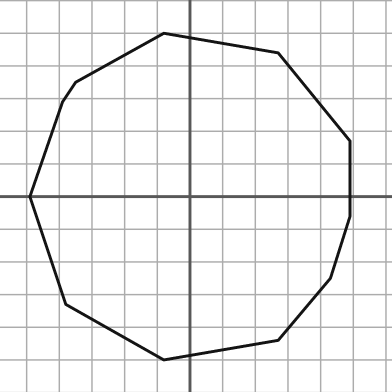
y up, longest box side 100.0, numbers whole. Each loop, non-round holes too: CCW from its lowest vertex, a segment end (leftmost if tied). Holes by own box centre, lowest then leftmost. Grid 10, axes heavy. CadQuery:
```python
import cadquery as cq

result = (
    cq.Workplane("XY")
    .moveTo(-8.0, -50.0)
    .lineTo(27.0, -44.0)
    .lineTo(43.0, -25.0)
    .lineTo(49.0, -6.0)
    .lineTo(49.0, 17.0)
    .lineTo(27.0, 44.0)
    .lineTo(-8.0, 50.0)
    .lineTo(-35.0, 35.0)
    .lineTo(-39.0, 29.0)
    .lineTo(-49.0, 0.0)
    .lineTo(-38.0, -33.0)
    .close()
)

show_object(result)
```